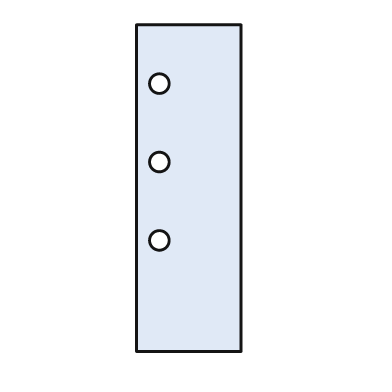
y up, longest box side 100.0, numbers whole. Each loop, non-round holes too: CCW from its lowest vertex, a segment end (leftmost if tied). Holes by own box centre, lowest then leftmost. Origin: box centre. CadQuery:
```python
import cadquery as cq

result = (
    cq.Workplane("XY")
    .moveTo(-16.0, -50.0)
    .lineTo(16.0, -50.0)
    .lineTo(16.0, 50.0)
    .lineTo(-16.0, 50.0)
    .close()
    .moveTo(-9.0, -16.0)
    .circle(3.0)
    .moveTo(-9.0, 8.0)
    .circle(3.0)
    .moveTo(-9.0, 32.0)
    .circle(3.0)
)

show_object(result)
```